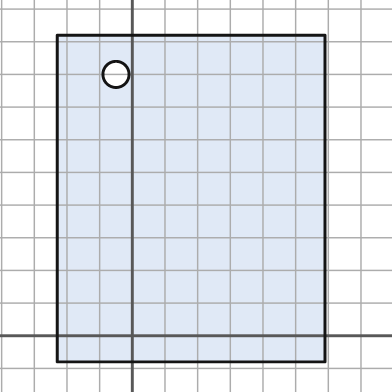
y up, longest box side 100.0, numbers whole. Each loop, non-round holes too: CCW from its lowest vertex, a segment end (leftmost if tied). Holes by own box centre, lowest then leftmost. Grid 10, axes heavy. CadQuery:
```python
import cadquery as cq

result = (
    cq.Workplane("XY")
    .moveTo(-23.0, -8.0)
    .lineTo(59.0, -8.0)
    .lineTo(59.0, 92.0)
    .lineTo(-23.0, 92.0)
    .close()
    .moveTo(-5.0, 80.0)
    .circle(4.0)
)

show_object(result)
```